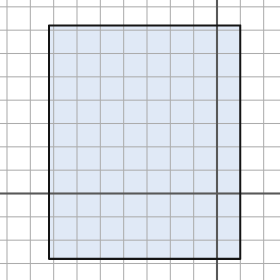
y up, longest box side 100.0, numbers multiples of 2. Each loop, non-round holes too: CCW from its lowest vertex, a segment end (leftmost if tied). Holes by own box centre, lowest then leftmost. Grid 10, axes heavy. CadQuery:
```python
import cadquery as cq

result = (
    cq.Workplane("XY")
    .moveTo(-72.0, -28.0)
    .lineTo(10.0, -28.0)
    .lineTo(10.0, 72.0)
    .lineTo(-72.0, 72.0)
    .close()
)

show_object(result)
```